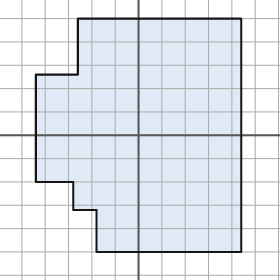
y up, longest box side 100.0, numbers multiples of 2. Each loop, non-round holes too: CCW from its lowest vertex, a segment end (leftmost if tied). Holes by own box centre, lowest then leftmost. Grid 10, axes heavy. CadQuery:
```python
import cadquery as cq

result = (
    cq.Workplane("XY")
    .moveTo(-18.0, -50.0)
    .lineTo(44.0, -50.0)
    .lineTo(44.0, 50.0)
    .lineTo(-26.0, 50.0)
    .lineTo(-26.0, 26.0)
    .lineTo(-44.0, 26.0)
    .lineTo(-44.0, -20.0)
    .lineTo(-28.0, -20.0)
    .lineTo(-28.0, -32.0)
    .lineTo(-18.0, -32.0)
    .close()
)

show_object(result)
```